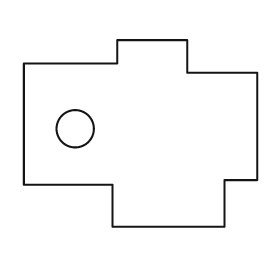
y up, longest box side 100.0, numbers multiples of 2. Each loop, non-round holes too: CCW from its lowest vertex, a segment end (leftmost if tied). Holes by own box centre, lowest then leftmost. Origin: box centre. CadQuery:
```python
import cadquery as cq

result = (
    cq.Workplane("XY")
    .moveTo(-12.0, -40.0)
    .lineTo(36.0, -40.0)
    .lineTo(36.0, -20.0)
    .lineTo(50.0, -20.0)
    .lineTo(50.0, 26.0)
    .lineTo(20.0, 26.0)
    .lineTo(20.0, 40.0)
    .lineTo(-10.0, 40.0)
    .lineTo(-10.0, 30.0)
    .lineTo(-50.0, 30.0)
    .lineTo(-50.0, -22.0)
    .lineTo(-12.0, -22.0)
    .close()
    .moveTo(-28.0, 2.0)
    .circle(8.0)
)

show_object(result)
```